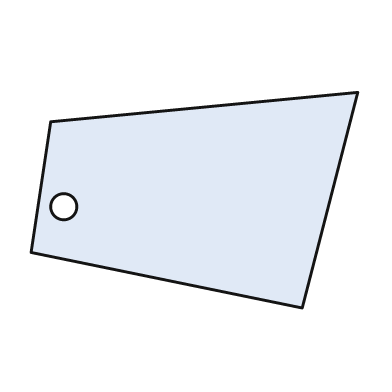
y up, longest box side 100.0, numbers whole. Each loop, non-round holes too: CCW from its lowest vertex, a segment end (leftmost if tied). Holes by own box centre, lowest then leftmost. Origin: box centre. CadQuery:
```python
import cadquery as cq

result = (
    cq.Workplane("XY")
    .moveTo(33.0, -33.0)
    .lineTo(50.0, 33.0)
    .lineTo(-44.0, 24.0)
    .lineTo(-50.0, -16.0)
    .close()
    .moveTo(-40.0, -2.0)
    .circle(4.0)
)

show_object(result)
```